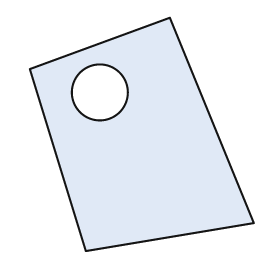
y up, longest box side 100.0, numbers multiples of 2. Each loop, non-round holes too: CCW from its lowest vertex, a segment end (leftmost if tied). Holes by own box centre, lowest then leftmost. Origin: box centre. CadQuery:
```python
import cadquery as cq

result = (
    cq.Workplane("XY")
    .moveTo(-24.0, -50.0)
    .lineTo(48.0, -38.0)
    .lineTo(12.0, 50.0)
    .lineTo(-48.0, 28.0)
    .close()
    .moveTo(-18.0, 18.0)
    .circle(12.0)
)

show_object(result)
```